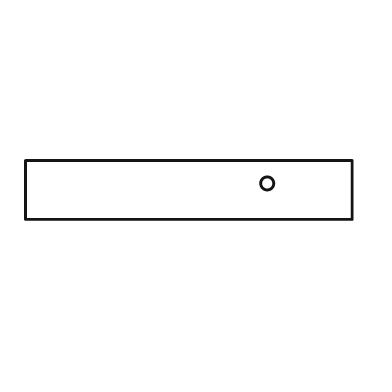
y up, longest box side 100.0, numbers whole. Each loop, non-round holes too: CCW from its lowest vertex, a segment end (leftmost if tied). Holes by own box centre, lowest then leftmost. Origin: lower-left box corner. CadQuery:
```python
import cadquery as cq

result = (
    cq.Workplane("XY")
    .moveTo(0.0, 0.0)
    .lineTo(100.0, 0.0)
    .lineTo(100.0, 18.0)
    .lineTo(0.0, 18.0)
    .close()
    .moveTo(74.0, 11.0)
    .circle(2.0)
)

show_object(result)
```